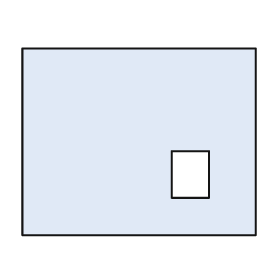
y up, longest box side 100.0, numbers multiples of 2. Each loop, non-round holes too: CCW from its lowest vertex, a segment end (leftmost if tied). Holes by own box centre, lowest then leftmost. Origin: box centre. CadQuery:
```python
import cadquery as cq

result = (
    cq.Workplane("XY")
    .moveTo(-50.0, -40.0)
    .lineTo(50.0, -40.0)
    .lineTo(50.0, 40.0)
    .lineTo(-50.0, 40.0)
    .close()
    .moveTo(14.0, -24.0)
    .lineTo(30.0, -24.0)
    .lineTo(30.0, -4.0)
    .lineTo(14.0, -4.0)
    .close()
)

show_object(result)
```